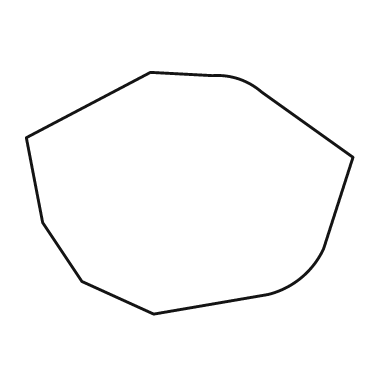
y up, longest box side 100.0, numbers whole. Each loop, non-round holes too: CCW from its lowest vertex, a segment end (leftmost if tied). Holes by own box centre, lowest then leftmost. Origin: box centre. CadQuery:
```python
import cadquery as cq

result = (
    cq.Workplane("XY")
    .moveTo(-11.0, -37.0)
    .lineTo(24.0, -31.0)
    .threePointArc((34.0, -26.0), (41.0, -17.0))
    .lineTo(50.0, 11.0)
    .lineTo(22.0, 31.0)
    .threePointArc((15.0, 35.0), (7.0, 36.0))
    .lineTo(-12.0, 37.0)
    .lineTo(-50.0, 17.0)
    .lineTo(-45.0, -9.0)
    .lineTo(-33.0, -27.0)
    .close()
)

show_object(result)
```